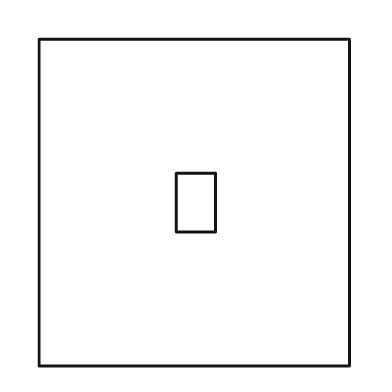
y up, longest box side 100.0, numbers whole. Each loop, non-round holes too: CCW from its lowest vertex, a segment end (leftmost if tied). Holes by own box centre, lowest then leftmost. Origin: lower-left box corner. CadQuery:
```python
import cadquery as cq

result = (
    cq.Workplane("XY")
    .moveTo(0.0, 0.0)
    .lineTo(95.0, 0.0)
    .lineTo(95.0, 100.0)
    .lineTo(0.0, 100.0)
    .close()
    .moveTo(42.0, 41.0)
    .lineTo(54.0, 41.0)
    .lineTo(54.0, 59.0)
    .lineTo(42.0, 59.0)
    .close()
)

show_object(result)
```